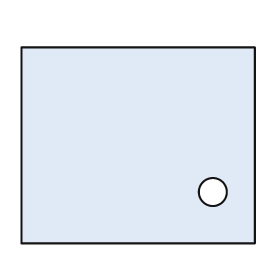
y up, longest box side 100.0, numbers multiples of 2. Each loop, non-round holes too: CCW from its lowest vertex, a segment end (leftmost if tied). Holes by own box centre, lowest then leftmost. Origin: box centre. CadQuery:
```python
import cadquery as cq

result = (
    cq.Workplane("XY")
    .moveTo(-50.0, -42.0)
    .lineTo(50.0, -42.0)
    .lineTo(50.0, 42.0)
    .lineTo(-50.0, 42.0)
    .close()
    .moveTo(32.0, -20.0)
    .circle(6.0)
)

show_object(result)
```